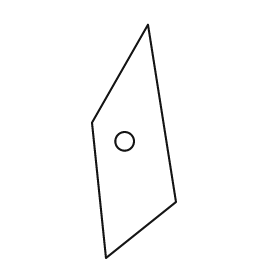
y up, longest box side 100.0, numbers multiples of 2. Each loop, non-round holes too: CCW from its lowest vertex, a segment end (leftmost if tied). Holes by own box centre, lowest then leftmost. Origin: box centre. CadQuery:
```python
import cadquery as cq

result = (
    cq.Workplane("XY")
    .moveTo(-12.0, -50.0)
    .lineTo(18.0, -26.0)
    .lineTo(6.0, 50.0)
    .lineTo(-18.0, 8.0)
    .close()
    .moveTo(-4.0, 0.0)
    .circle(4.0)
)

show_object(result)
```